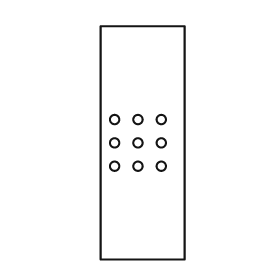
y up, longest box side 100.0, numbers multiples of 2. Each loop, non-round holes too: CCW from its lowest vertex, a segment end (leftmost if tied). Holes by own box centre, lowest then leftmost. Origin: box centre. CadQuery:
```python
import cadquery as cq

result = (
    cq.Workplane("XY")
    .moveTo(-18.0, -50.0)
    .lineTo(18.0, -50.0)
    .lineTo(18.0, 50.0)
    .lineTo(-18.0, 50.0)
    .close()
    .moveTo(-12.0, -10.0)
    .circle(2.0)
    .moveTo(-2.0, -10.0)
    .circle(2.0)
    .moveTo(8.0, -10.0)
    .circle(2.0)
    .moveTo(-12.0, 0.0)
    .circle(2.0)
    .moveTo(-2.0, 0.0)
    .circle(2.0)
    .moveTo(8.0, 0.0)
    .circle(2.0)
    .moveTo(-12.0, 10.0)
    .circle(2.0)
    .moveTo(-2.0, 10.0)
    .circle(2.0)
    .moveTo(8.0, 10.0)
    .circle(2.0)
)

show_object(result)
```